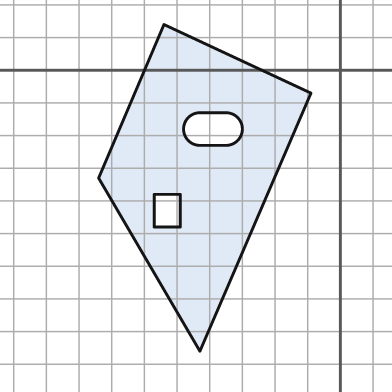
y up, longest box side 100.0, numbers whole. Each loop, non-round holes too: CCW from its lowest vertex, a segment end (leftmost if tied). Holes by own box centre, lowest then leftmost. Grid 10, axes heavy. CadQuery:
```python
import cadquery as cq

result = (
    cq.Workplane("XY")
    .moveTo(-43.0, -86.0)
    .lineTo(-9.0, -7.0)
    .lineTo(-54.0, 14.0)
    .lineTo(-74.0, -33.0)
    .close()
    .moveTo(-57.0, -48.0)
    .lineTo(-49.0, -48.0)
    .lineTo(-49.0, -38.0)
    .lineTo(-57.0, -38.0)
    .close()
    .moveTo(-43.0, -23.0)
    .lineTo(-35.0, -23.0)
    .threePointArc((-30.0, -18.0), (-35.0, -13.0))
    .lineTo(-43.0, -13.0)
    .threePointArc((-48.0, -18.0), (-43.0, -23.0))
    .close()
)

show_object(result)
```